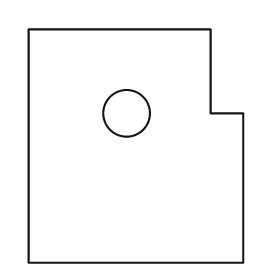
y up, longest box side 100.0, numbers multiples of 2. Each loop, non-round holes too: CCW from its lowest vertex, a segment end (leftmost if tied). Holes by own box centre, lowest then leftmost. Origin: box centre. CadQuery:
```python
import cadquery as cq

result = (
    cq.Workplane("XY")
    .moveTo(-46.0, -50.0)
    .lineTo(46.0, -50.0)
    .lineTo(46.0, 14.0)
    .lineTo(32.0, 14.0)
    .lineTo(32.0, 50.0)
    .lineTo(-46.0, 50.0)
    .close()
    .moveTo(-4.0, 14.0)
    .circle(10.0)
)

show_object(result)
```